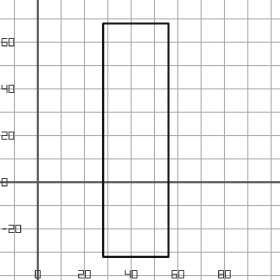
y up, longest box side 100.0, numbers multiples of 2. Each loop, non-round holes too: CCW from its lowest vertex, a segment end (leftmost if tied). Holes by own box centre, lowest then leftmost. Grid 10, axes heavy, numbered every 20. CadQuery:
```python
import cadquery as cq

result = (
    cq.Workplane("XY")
    .moveTo(28.0, -32.0)
    .lineTo(56.0, -32.0)
    .lineTo(56.0, 68.0)
    .lineTo(28.0, 68.0)
    .close()
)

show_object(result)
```